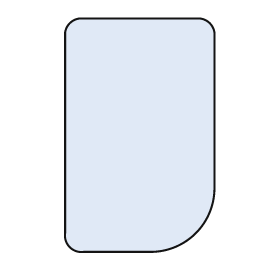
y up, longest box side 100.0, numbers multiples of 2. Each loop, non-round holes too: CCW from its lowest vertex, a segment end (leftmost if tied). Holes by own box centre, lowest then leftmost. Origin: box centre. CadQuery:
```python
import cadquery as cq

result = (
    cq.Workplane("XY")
    .moveTo(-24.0, -50.0)
    .lineTo(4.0, -50.0)
    .threePointArc((24.0, -42.0), (32.0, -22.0))
    .lineTo(32.0, 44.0)
    .threePointArc((30.0, 48.0), (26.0, 50.0))
    .lineTo(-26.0, 50.0)
    .threePointArc((-30.0, 48.0), (-32.0, 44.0))
    .lineTo(-32.0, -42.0)
    .threePointArc((-30.0, -48.0), (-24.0, -50.0))
    .close()
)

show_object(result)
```